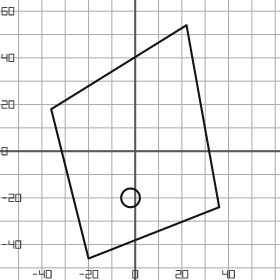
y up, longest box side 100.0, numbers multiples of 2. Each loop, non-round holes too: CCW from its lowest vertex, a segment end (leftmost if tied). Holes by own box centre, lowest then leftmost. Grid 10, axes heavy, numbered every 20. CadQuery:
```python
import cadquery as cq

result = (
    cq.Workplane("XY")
    .moveTo(-20.0, -46.0)
    .lineTo(36.0, -24.0)
    .lineTo(22.0, 54.0)
    .lineTo(-36.0, 18.0)
    .close()
    .moveTo(-2.0, -20.0)
    .circle(4.0)
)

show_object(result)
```